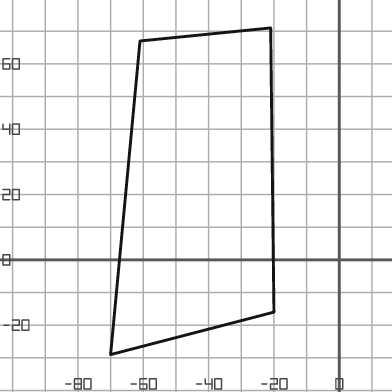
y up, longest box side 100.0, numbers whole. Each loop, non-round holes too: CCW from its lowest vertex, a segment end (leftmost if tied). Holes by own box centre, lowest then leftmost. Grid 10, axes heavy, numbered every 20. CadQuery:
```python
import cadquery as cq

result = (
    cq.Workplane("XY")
    .moveTo(-70.0, -29.0)
    .lineTo(-20.0, -16.0)
    .lineTo(-21.0, 71.0)
    .lineTo(-61.0, 67.0)
    .close()
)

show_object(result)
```